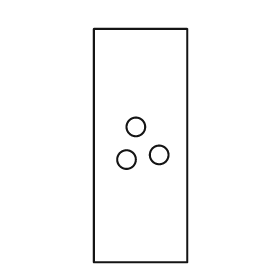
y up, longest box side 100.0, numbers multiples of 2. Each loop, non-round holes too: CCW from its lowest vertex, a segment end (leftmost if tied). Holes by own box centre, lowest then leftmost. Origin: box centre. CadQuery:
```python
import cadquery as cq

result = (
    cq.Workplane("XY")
    .moveTo(-20.0, -50.0)
    .lineTo(20.0, -50.0)
    .lineTo(20.0, 50.0)
    .lineTo(-20.0, 50.0)
    .close()
    .moveTo(-6.0, -6.0)
    .circle(4.0)
    .moveTo(8.0, -4.0)
    .circle(4.0)
    .moveTo(-2.0, 8.0)
    .circle(4.0)
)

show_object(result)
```